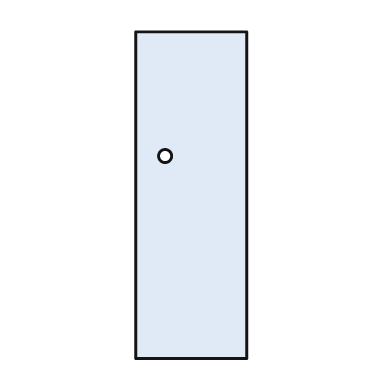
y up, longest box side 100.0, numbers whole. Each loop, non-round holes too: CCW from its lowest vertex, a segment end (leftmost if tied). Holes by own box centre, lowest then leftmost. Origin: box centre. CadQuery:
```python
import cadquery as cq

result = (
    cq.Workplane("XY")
    .moveTo(-17.0, -50.0)
    .lineTo(17.0, -50.0)
    .lineTo(17.0, 50.0)
    .lineTo(-17.0, 50.0)
    .close()
    .moveTo(-8.0, 12.0)
    .circle(2.0)
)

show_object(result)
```